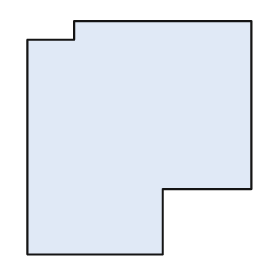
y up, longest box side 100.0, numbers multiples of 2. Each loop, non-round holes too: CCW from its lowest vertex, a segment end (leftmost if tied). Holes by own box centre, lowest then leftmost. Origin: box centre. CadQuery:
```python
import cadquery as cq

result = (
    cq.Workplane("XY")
    .moveTo(-48.0, -50.0)
    .lineTo(10.0, -50.0)
    .lineTo(10.0, -22.0)
    .lineTo(48.0, -22.0)
    .lineTo(48.0, 50.0)
    .lineTo(-28.0, 50.0)
    .lineTo(-28.0, 42.0)
    .lineTo(-48.0, 42.0)
    .close()
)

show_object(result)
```